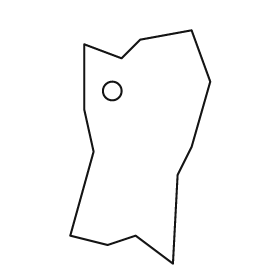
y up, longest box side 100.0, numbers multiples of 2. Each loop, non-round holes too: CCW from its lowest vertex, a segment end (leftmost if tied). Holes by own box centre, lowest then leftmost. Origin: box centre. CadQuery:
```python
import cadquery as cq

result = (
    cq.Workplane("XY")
    .moveTo(14.0, -50.0)
    .lineTo(16.0, -12.0)
    .lineTo(22.0, 0.0)
    .lineTo(30.0, 28.0)
    .lineTo(22.0, 50.0)
    .lineTo(0.0, 46.0)
    .lineTo(-8.0, 38.0)
    .lineTo(-24.0, 44.0)
    .lineTo(-24.0, 16.0)
    .lineTo(-20.0, -2.0)
    .lineTo(-30.0, -38.0)
    .lineTo(-14.0, -42.0)
    .lineTo(-2.0, -38.0)
    .close()
    .moveTo(-12.0, 24.0)
    .circle(4.0)
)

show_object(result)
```